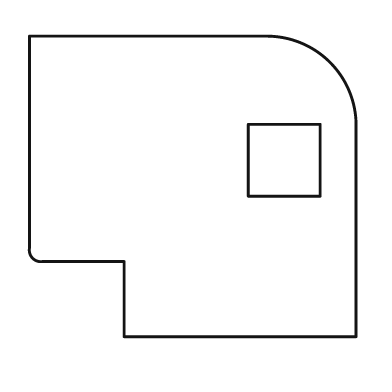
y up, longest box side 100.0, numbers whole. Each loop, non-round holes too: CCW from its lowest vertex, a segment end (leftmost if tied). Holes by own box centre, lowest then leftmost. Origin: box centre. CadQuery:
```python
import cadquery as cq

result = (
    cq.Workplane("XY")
    .moveTo(-21.0, -46.0)
    .lineTo(50.0, -46.0)
    .lineTo(50.0, 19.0)
    .threePointArc((42.0, 38.0), (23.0, 46.0))
    .lineTo(-50.0, 46.0)
    .lineTo(-50.0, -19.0)
    .threePointArc((-49.0, -22.0), (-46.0, -23.0))
    .lineTo(-21.0, -23.0)
    .close()
    .moveTo(17.0, -3.0)
    .lineTo(39.0, -3.0)
    .lineTo(39.0, 19.0)
    .lineTo(17.0, 19.0)
    .close()
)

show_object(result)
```